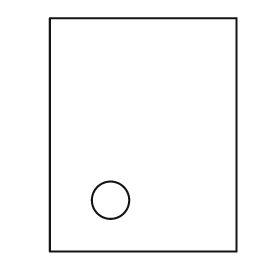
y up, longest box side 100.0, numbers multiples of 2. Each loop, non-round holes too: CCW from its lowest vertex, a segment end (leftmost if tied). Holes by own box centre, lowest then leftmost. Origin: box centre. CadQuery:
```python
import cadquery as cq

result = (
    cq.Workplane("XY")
    .moveTo(-40.0, -50.0)
    .lineTo(40.0, -50.0)
    .lineTo(40.0, 50.0)
    .lineTo(-40.0, 50.0)
    .close()
    .moveTo(-14.0, -28.0)
    .circle(8.0)
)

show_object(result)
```